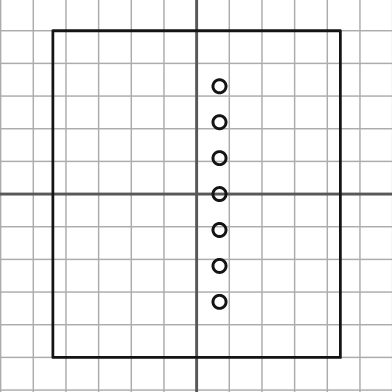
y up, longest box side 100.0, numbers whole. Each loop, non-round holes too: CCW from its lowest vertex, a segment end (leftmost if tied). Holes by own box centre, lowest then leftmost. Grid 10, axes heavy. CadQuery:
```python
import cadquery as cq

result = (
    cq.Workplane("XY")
    .moveTo(-44.0, -50.0)
    .lineTo(44.0, -50.0)
    .lineTo(44.0, 50.0)
    .lineTo(-44.0, 50.0)
    .close()
    .moveTo(7.0, -33.0)
    .circle(2.0)
    .moveTo(7.0, -22.0)
    .circle(2.0)
    .moveTo(7.0, -11.0)
    .circle(2.0)
    .moveTo(7.0, 0.0)
    .circle(2.0)
    .moveTo(7.0, 11.0)
    .circle(2.0)
    .moveTo(7.0, 22.0)
    .circle(2.0)
    .moveTo(7.0, 33.0)
    .circle(2.0)
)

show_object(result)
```